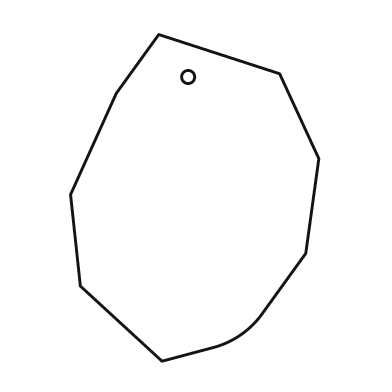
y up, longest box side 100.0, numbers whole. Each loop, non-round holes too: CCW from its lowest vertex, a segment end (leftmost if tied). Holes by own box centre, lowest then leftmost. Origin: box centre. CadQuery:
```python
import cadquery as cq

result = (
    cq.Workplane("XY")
    .moveTo(-10.0, -50.0)
    .lineTo(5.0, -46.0)
    .threePointArc((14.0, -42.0), (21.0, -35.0))
    .lineTo(34.0, -17.0)
    .lineTo(38.0, 12.0)
    .lineTo(26.0, 38.0)
    .lineTo(-11.0, 50.0)
    .lineTo(-24.0, 32.0)
    .lineTo(-38.0, 1.0)
    .lineTo(-35.0, -27.0)
    .close()
    .moveTo(-2.0, 37.0)
    .circle(2.0)
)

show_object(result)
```